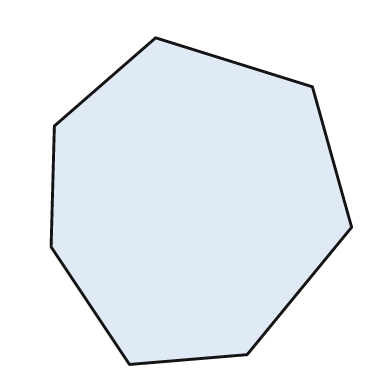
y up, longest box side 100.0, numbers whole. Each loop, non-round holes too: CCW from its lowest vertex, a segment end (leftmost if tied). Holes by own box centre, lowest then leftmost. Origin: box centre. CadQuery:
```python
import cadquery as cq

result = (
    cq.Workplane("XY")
    .moveTo(-22.0, -50.0)
    .lineTo(14.0, -47.0)
    .lineTo(46.0, -8.0)
    .lineTo(34.0, 35.0)
    .lineTo(-14.0, 50.0)
    .lineTo(-45.0, 23.0)
    .lineTo(-46.0, -14.0)
    .close()
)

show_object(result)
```